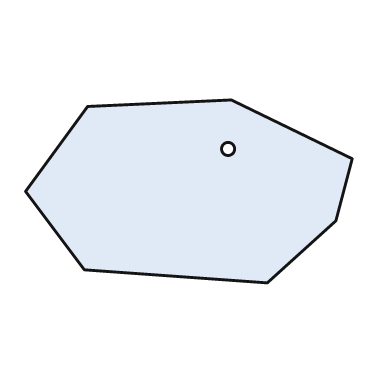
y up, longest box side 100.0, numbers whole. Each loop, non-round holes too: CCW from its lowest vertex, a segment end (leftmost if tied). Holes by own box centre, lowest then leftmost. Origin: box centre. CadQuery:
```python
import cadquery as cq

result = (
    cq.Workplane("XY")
    .moveTo(24.0, -28.0)
    .lineTo(45.0, -9.0)
    .lineTo(50.0, 10.0)
    .lineTo(13.0, 28.0)
    .lineTo(-31.0, 26.0)
    .lineTo(-50.0, 0.0)
    .lineTo(-32.0, -24.0)
    .close()
    .moveTo(12.0, 13.0)
    .circle(2.0)
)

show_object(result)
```